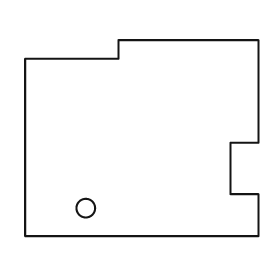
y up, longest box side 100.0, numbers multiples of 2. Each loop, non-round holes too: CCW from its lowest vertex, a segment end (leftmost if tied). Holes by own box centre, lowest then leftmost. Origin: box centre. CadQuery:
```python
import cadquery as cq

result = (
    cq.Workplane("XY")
    .moveTo(-50.0, -42.0)
    .lineTo(50.0, -42.0)
    .lineTo(50.0, -24.0)
    .lineTo(38.0, -24.0)
    .lineTo(38.0, -2.0)
    .lineTo(50.0, -2.0)
    .lineTo(50.0, 42.0)
    .lineTo(-10.0, 42.0)
    .lineTo(-10.0, 34.0)
    .lineTo(-50.0, 34.0)
    .close()
    .moveTo(-24.0, -30.0)
    .circle(4.0)
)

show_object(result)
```